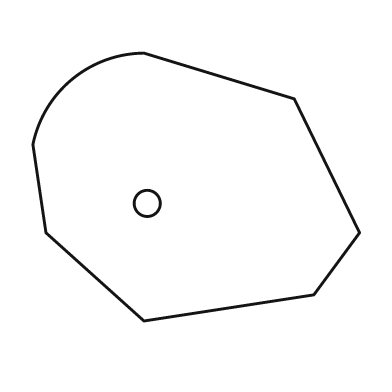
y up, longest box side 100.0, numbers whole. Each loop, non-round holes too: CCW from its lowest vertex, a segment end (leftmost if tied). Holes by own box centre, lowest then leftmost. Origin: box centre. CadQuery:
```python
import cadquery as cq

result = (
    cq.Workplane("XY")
    .moveTo(-16.0, -41.0)
    .lineTo(36.0, -33.0)
    .lineTo(50.0, -14.0)
    .lineTo(30.0, 27.0)
    .lineTo(-16.0, 41.0)
    .threePointArc((-38.0, 33.0), (-50.0, 13.0))
    .lineTo(-46.0, -14.0)
    .close()
    .moveTo(-15.0, -5.0)
    .circle(4.0)
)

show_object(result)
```